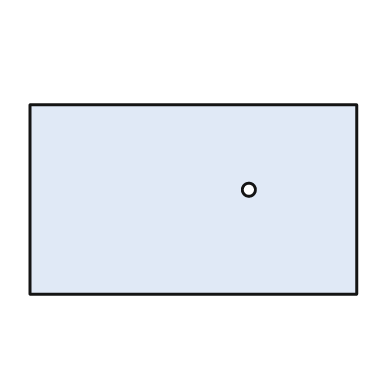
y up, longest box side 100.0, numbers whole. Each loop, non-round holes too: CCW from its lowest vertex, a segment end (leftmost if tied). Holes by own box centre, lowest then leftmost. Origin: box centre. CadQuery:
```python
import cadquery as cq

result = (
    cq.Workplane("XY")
    .moveTo(-50.0, -29.0)
    .lineTo(50.0, -29.0)
    .lineTo(50.0, 29.0)
    .lineTo(-50.0, 29.0)
    .close()
    .moveTo(17.0, 3.0)
    .circle(2.0)
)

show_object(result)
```